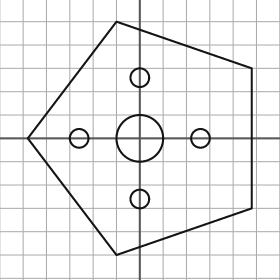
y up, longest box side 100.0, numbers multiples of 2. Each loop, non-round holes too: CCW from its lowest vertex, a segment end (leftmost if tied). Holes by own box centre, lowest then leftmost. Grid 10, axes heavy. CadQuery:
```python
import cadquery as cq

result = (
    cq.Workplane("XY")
    .moveTo(-10.0, -50.0)
    .lineTo(48.0, -30.0)
    .lineTo(48.0, 30.0)
    .lineTo(-10.0, 50.0)
    .lineTo(-48.0, 0.0)
    .close()
    .moveTo(0.0, -26.0)
    .circle(4.0)
    .moveTo(-26.0, 0.0)
    .circle(4.0)
    .moveTo(0.0, 0.0)
    .circle(10.0)
    .moveTo(26.0, 0.0)
    .circle(4.0)
    .moveTo(0.0, 26.0)
    .circle(4.0)
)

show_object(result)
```